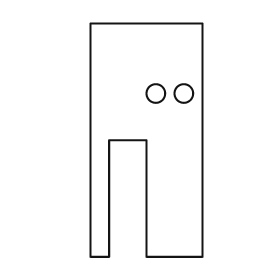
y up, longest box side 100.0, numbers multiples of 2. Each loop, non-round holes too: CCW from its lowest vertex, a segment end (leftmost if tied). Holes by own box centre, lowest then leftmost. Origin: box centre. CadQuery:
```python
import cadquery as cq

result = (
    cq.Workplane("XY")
    .moveTo(-24.0, -50.0)
    .lineTo(-16.0, -50.0)
    .lineTo(-16.0, 0.0)
    .lineTo(0.0, 0.0)
    .lineTo(0.0, -50.0)
    .lineTo(24.0, -50.0)
    .lineTo(24.0, 50.0)
    .lineTo(-24.0, 50.0)
    .close()
    .moveTo(4.0, 20.0)
    .circle(4.0)
    .moveTo(16.0, 20.0)
    .circle(4.0)
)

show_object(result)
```